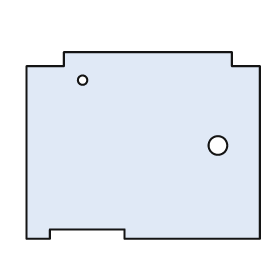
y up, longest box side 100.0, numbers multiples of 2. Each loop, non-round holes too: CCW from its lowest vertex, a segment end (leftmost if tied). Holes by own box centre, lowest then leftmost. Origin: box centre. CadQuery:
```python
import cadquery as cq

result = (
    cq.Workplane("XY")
    .moveTo(-50.0, -40.0)
    .lineTo(-40.0, -40.0)
    .lineTo(-40.0, -36.0)
    .lineTo(-8.0, -36.0)
    .lineTo(-8.0, -40.0)
    .lineTo(50.0, -40.0)
    .lineTo(50.0, 34.0)
    .lineTo(38.0, 34.0)
    .lineTo(38.0, 40.0)
    .lineTo(-34.0, 40.0)
    .lineTo(-34.0, 34.0)
    .lineTo(-50.0, 34.0)
    .close()
    .moveTo(32.0, 0.0)
    .circle(4.0)
    .moveTo(-26.0, 28.0)
    .circle(2.0)
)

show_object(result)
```